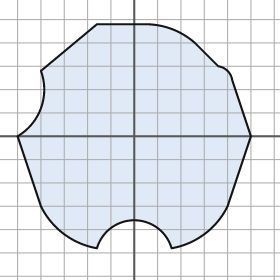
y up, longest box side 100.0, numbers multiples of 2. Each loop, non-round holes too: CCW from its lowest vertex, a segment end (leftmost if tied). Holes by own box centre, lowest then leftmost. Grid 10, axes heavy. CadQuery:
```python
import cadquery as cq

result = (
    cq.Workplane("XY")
    .moveTo(-16.0, -48.0)
    .threePointArc((0.0, -36.0), (16.0, -48.0))
    .threePointArc((30.0, -42.0), (40.0, -30.0))
    .lineTo(50.0, 0.0)
    .lineTo(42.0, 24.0)
    .threePointArc((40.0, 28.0), (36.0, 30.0))
    .lineTo(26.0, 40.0)
    .threePointArc((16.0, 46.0), (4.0, 48.0))
    .lineTo(-16.0, 48.0)
    .lineTo(-40.0, 28.0)
    .threePointArc((-40.0, 12.0), (-50.0, 0.0))
    .lineTo(-40.0, -30.0)
    .threePointArc((-30.0, -42.0), (-16.0, -48.0))
    .close()
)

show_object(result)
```